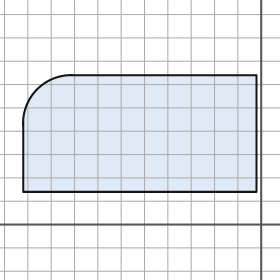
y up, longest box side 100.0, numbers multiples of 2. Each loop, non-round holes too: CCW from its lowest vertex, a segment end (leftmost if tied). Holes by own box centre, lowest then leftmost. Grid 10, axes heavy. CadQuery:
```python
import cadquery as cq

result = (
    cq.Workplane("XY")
    .moveTo(-102.0, 14.0)
    .lineTo(-2.0, 14.0)
    .lineTo(-2.0, 64.0)
    .lineTo(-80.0, 64.0)
    .threePointArc((-96.0, 58.0), (-102.0, 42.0))
    .close()
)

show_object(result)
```